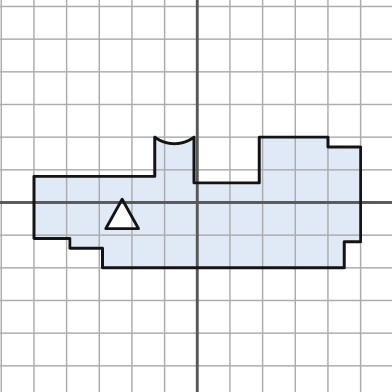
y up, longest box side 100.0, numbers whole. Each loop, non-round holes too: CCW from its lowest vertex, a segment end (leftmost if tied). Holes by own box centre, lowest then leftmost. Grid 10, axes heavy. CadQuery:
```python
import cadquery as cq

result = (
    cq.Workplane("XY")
    .moveTo(-29.0, -20.0)
    .lineTo(45.0, -20.0)
    .lineTo(45.0, -12.0)
    .lineTo(50.0, -12.0)
    .lineTo(50.0, 17.0)
    .lineTo(40.0, 17.0)
    .lineTo(40.0, 20.0)
    .lineTo(19.0, 20.0)
    .lineTo(19.0, 6.0)
    .lineTo(-1.0, 6.0)
    .lineTo(-1.0, 20.0)
    .threePointArc((-7.0, 18.0), (-13.0, 20.0))
    .lineTo(-13.0, 8.0)
    .lineTo(-50.0, 8.0)
    .lineTo(-50.0, -11.0)
    .lineTo(-39.0, -11.0)
    .lineTo(-39.0, -14.0)
    .lineTo(-29.0, -14.0)
    .close()
    .moveTo(-28.0, -8.0)
    .lineTo(-18.0, -8.0)
    .lineTo(-23.0, 1.0)
    .close()
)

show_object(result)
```